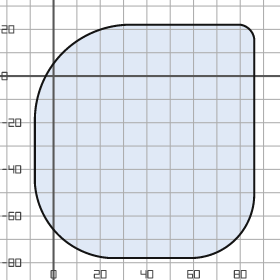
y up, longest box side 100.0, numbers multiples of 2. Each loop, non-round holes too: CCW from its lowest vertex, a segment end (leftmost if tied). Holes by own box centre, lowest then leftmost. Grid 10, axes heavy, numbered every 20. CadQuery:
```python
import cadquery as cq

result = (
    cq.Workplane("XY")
    .moveTo(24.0, -78.0)
    .lineTo(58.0, -78.0)
    .threePointArc((78.0, -70.0), (86.0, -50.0))
    .lineTo(86.0, 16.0)
    .threePointArc((84.0, 20.0), (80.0, 22.0))
    .lineTo(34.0, 22.0)
    .threePointArc((4.0, 10.0), (-8.0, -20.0))
    .lineTo(-8.0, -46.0)
    .threePointArc((2.0, -68.0), (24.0, -78.0))
    .close()
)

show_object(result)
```